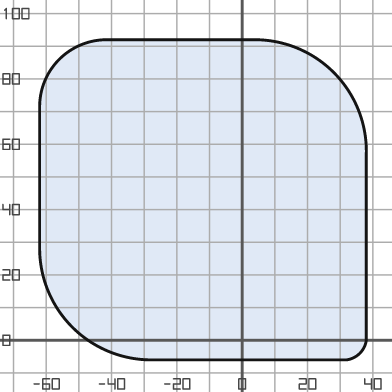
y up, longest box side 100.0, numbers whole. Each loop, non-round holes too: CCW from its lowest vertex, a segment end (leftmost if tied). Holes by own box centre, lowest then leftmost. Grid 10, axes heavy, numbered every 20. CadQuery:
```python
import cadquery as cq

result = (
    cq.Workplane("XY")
    .moveTo(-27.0, -6.0)
    .lineTo(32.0, -6.0)
    .threePointArc((36.0, -4.0), (38.0, 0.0))
    .lineTo(38.0, 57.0)
    .threePointArc((28.0, 82.0), (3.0, 92.0))
    .lineTo(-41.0, 92.0)
    .threePointArc((-56.0, 86.0), (-62.0, 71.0))
    .lineTo(-62.0, 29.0)
    .threePointArc((-52.0, 4.0), (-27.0, -6.0))
    .close()
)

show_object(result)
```